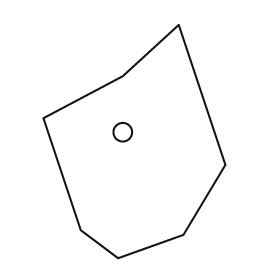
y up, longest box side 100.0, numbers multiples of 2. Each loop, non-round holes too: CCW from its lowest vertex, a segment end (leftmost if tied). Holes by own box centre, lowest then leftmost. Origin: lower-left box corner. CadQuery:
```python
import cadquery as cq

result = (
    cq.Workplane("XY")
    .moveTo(32.0, 0.0)
    .lineTo(60.0, 10.0)
    .lineTo(78.0, 40.0)
    .lineTo(58.0, 100.0)
    .lineTo(34.0, 78.0)
    .lineTo(0.0, 60.0)
    .lineTo(16.0, 12.0)
    .close()
    .moveTo(34.0, 54.0)
    .circle(4.0)
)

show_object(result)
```